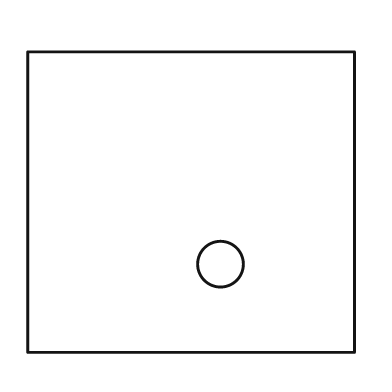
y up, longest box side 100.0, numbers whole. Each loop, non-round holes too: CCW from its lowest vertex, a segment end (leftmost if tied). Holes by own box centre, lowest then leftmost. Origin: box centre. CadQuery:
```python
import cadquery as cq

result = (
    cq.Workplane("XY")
    .moveTo(-50.0, -46.0)
    .lineTo(50.0, -46.0)
    .lineTo(50.0, 46.0)
    .lineTo(-50.0, 46.0)
    .close()
    .moveTo(9.0, -19.0)
    .circle(7.0)
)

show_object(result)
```